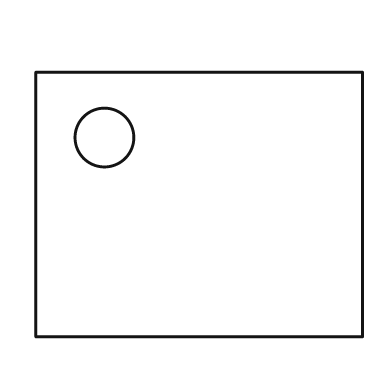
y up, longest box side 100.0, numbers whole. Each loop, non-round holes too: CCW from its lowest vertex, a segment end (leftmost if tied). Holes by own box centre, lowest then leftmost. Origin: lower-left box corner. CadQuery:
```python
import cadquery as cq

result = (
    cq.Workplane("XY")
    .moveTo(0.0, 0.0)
    .lineTo(100.0, 0.0)
    .lineTo(100.0, 81.0)
    .lineTo(0.0, 81.0)
    .close()
    .moveTo(21.0, 61.0)
    .circle(9.0)
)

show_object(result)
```